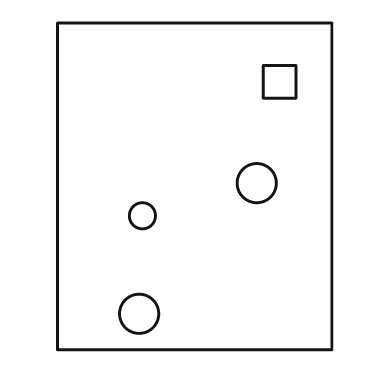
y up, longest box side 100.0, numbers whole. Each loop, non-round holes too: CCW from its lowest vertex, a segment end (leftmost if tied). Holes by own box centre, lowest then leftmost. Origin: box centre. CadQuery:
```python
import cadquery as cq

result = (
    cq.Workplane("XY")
    .moveTo(-42.0, -50.0)
    .lineTo(42.0, -50.0)
    .lineTo(42.0, 50.0)
    .lineTo(-42.0, 50.0)
    .close()
    .moveTo(-17.0, -39.0)
    .circle(6.0)
    .moveTo(-16.0, -9.0)
    .circle(4.0)
    .moveTo(19.0, 1.0)
    .circle(6.0)
    .moveTo(21.0, 27.0)
    .lineTo(31.0, 27.0)
    .lineTo(31.0, 37.0)
    .lineTo(21.0, 37.0)
    .close()
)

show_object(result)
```